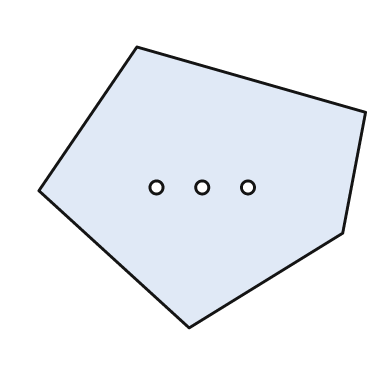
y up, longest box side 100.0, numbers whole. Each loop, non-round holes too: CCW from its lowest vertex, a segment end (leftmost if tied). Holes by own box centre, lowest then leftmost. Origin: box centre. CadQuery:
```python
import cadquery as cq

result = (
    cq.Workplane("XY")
    .moveTo(-4.0, -43.0)
    .lineTo(43.0, -14.0)
    .lineTo(50.0, 23.0)
    .lineTo(-20.0, 43.0)
    .lineTo(-50.0, -1.0)
    .close()
    .moveTo(-14.0, 0.0)
    .circle(2.0)
    .moveTo(0.0, 0.0)
    .circle(2.0)
    .moveTo(14.0, 0.0)
    .circle(2.0)
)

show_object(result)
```